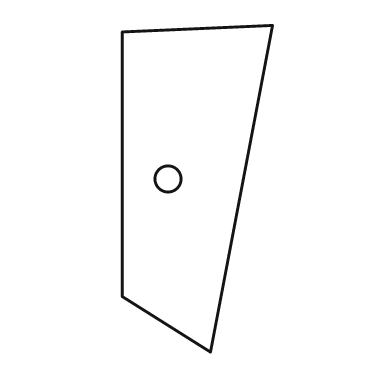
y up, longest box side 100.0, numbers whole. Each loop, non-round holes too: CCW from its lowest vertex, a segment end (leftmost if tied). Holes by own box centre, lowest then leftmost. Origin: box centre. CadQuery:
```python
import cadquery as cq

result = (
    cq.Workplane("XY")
    .moveTo(4.0, -50.0)
    .lineTo(23.0, 50.0)
    .lineTo(-23.0, 48.0)
    .lineTo(-23.0, -33.0)
    .close()
    .moveTo(-9.0, 3.0)
    .circle(4.0)
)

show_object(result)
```